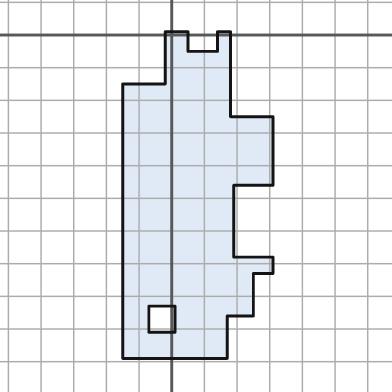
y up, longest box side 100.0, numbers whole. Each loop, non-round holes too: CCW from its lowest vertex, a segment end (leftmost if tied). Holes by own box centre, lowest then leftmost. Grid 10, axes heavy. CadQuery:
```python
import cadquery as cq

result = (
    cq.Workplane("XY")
    .moveTo(-15.0, -99.0)
    .lineTo(17.0, -99.0)
    .lineTo(17.0, -86.0)
    .lineTo(25.0, -86.0)
    .lineTo(25.0, -73.0)
    .lineTo(31.0, -73.0)
    .lineTo(31.0, -68.0)
    .lineTo(19.0, -68.0)
    .lineTo(19.0, -46.0)
    .lineTo(31.0, -46.0)
    .lineTo(31.0, -25.0)
    .lineTo(18.0, -25.0)
    .lineTo(18.0, 1.0)
    .lineTo(14.0, 1.0)
    .lineTo(14.0, -5.0)
    .lineTo(5.0, -5.0)
    .lineTo(5.0, 1.0)
    .lineTo(-2.0, 1.0)
    .lineTo(-2.0, -15.0)
    .lineTo(-15.0, -15.0)
    .close()
    .moveTo(-7.0, -91.0)
    .lineTo(1.0, -91.0)
    .lineTo(1.0, -83.0)
    .lineTo(-7.0, -83.0)
    .close()
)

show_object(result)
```